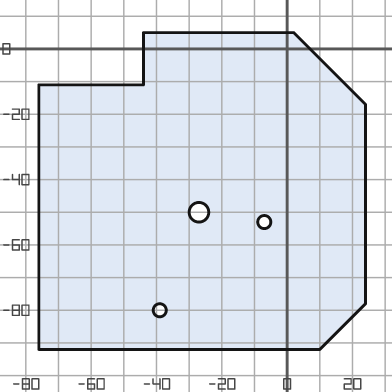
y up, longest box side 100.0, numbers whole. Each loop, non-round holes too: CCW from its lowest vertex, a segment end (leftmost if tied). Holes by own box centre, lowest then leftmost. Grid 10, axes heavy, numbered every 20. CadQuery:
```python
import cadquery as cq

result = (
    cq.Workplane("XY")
    .moveTo(-76.0, -92.0)
    .lineTo(10.0, -92.0)
    .lineTo(24.0, -78.0)
    .lineTo(24.0, -17.0)
    .lineTo(2.0, 5.0)
    .lineTo(-44.0, 5.0)
    .lineTo(-44.0, -11.0)
    .lineTo(-76.0, -11.0)
    .close()
    .moveTo(-39.0, -80.0)
    .circle(2.0)
    .moveTo(-7.0, -53.0)
    .circle(2.0)
    .moveTo(-27.0, -50.0)
    .circle(3.0)
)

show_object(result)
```